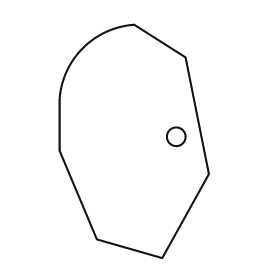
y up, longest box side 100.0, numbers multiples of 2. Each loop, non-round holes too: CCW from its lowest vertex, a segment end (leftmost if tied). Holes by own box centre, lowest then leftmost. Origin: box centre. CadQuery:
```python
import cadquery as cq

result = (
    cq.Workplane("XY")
    .moveTo(12.0, -50.0)
    .lineTo(32.0, -14.0)
    .lineTo(22.0, 36.0)
    .lineTo(0.0, 50.0)
    .threePointArc((-22.0, 40.0), (-32.0, 18.0))
    .lineTo(-32.0, -4.0)
    .lineTo(-16.0, -42.0)
    .close()
    .moveTo(18.0, 2.0)
    .circle(4.0)
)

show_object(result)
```